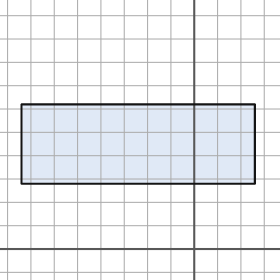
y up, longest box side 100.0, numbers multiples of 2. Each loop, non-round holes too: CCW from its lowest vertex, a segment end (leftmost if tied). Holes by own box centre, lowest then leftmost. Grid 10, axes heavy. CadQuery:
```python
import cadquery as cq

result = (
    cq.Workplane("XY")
    .moveTo(-74.0, 28.0)
    .lineTo(26.0, 28.0)
    .lineTo(26.0, 62.0)
    .lineTo(-74.0, 62.0)
    .close()
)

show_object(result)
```